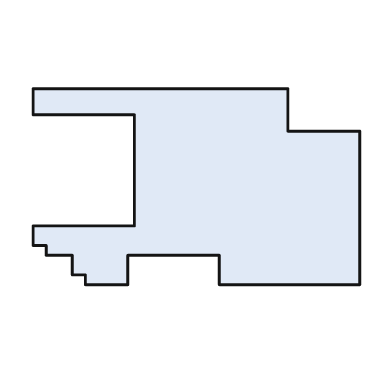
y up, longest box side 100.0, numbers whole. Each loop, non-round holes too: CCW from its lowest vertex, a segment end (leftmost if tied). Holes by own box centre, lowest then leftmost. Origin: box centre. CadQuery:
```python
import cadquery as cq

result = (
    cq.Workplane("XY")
    .moveTo(-34.0, -30.0)
    .lineTo(-21.0, -30.0)
    .lineTo(-21.0, -21.0)
    .lineTo(7.0, -21.0)
    .lineTo(7.0, -30.0)
    .lineTo(50.0, -30.0)
    .lineTo(50.0, 17.0)
    .lineTo(28.0, 17.0)
    .lineTo(28.0, 30.0)
    .lineTo(-50.0, 30.0)
    .lineTo(-50.0, 22.0)
    .lineTo(-19.0, 22.0)
    .lineTo(-19.0, -12.0)
    .lineTo(-50.0, -12.0)
    .lineTo(-50.0, -18.0)
    .lineTo(-46.0, -18.0)
    .lineTo(-46.0, -21.0)
    .lineTo(-38.0, -21.0)
    .lineTo(-38.0, -27.0)
    .lineTo(-34.0, -27.0)
    .close()
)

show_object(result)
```